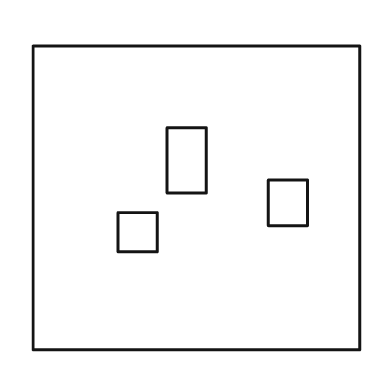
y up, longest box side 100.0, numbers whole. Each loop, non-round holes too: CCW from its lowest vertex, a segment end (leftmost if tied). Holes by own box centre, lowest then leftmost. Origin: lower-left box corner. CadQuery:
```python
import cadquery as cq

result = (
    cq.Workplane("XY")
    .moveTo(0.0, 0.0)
    .lineTo(100.0, 0.0)
    .lineTo(100.0, 93.0)
    .lineTo(0.0, 93.0)
    .close()
    .moveTo(26.0, 30.0)
    .lineTo(38.0, 30.0)
    .lineTo(38.0, 42.0)
    .lineTo(26.0, 42.0)
    .close()
    .moveTo(72.0, 38.0)
    .lineTo(84.0, 38.0)
    .lineTo(84.0, 52.0)
    .lineTo(72.0, 52.0)
    .close()
    .moveTo(41.0, 48.0)
    .lineTo(53.0, 48.0)
    .lineTo(53.0, 68.0)
    .lineTo(41.0, 68.0)
    .close()
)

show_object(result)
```